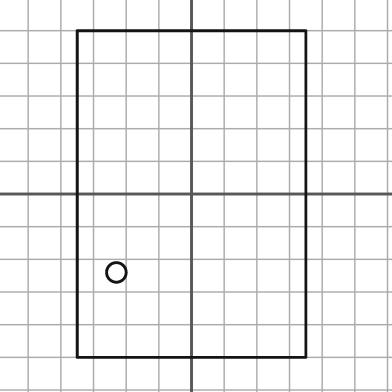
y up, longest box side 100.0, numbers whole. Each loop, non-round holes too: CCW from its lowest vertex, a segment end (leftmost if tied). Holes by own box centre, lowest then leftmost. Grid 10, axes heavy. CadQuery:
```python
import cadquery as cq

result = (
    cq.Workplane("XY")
    .moveTo(-35.0, -50.0)
    .lineTo(35.0, -50.0)
    .lineTo(35.0, 50.0)
    .lineTo(-35.0, 50.0)
    .close()
    .moveTo(-23.0, -24.0)
    .circle(3.0)
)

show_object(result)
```